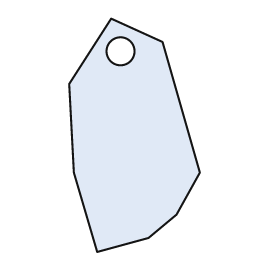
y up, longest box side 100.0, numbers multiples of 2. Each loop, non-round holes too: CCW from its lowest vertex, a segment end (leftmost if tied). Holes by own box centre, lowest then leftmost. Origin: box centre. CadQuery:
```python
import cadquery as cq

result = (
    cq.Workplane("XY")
    .moveTo(-16.0, -50.0)
    .lineTo(6.0, -44.0)
    .lineTo(18.0, -34.0)
    .lineTo(28.0, -16.0)
    .lineTo(12.0, 40.0)
    .lineTo(-10.0, 50.0)
    .lineTo(-28.0, 22.0)
    .lineTo(-26.0, -16.0)
    .close()
    .moveTo(-6.0, 36.0)
    .circle(6.0)
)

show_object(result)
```